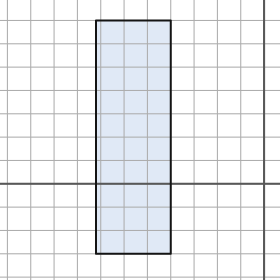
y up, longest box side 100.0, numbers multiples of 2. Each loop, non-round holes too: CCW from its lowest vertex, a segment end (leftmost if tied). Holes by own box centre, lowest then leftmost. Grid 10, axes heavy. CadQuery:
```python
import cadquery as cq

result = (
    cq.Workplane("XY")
    .moveTo(-72.0, -30.0)
    .lineTo(-40.0, -30.0)
    .lineTo(-40.0, 70.0)
    .lineTo(-72.0, 70.0)
    .close()
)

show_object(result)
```